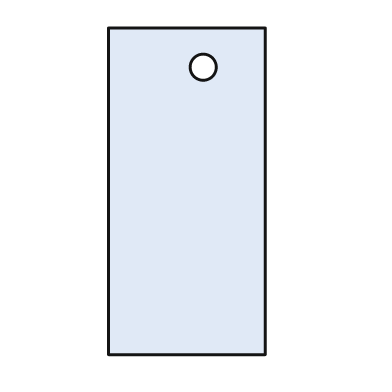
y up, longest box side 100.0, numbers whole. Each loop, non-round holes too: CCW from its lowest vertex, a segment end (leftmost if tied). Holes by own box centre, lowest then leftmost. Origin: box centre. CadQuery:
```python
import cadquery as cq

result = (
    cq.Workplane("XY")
    .moveTo(-24.0, -50.0)
    .lineTo(24.0, -50.0)
    .lineTo(24.0, 50.0)
    .lineTo(-24.0, 50.0)
    .close()
    .moveTo(5.0, 38.0)
    .circle(4.0)
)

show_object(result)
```